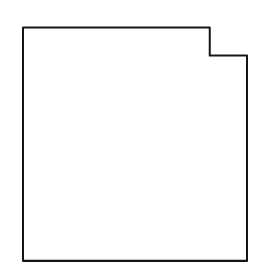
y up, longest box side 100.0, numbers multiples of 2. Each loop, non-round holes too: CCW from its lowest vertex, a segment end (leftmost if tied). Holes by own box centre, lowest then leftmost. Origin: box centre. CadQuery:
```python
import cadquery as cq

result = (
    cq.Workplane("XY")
    .moveTo(-48.0, -50.0)
    .lineTo(48.0, -50.0)
    .lineTo(48.0, 38.0)
    .lineTo(32.0, 38.0)
    .lineTo(32.0, 50.0)
    .lineTo(-48.0, 50.0)
    .close()
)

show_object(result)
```